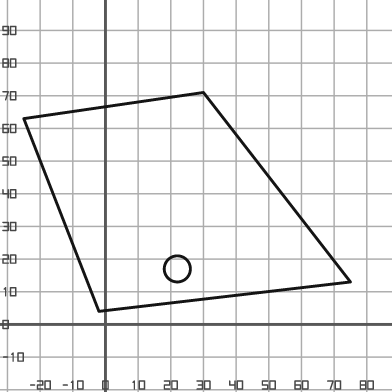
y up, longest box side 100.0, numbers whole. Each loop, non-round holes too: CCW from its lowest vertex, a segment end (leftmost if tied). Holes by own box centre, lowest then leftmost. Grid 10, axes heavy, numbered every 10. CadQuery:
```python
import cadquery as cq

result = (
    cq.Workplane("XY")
    .moveTo(-2.0, 4.0)
    .lineTo(75.0, 13.0)
    .lineTo(30.0, 71.0)
    .lineTo(-25.0, 63.0)
    .close()
    .moveTo(22.0, 17.0)
    .circle(4.0)
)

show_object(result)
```